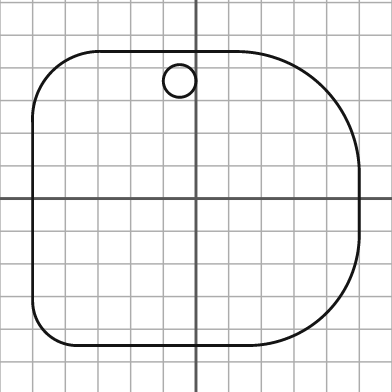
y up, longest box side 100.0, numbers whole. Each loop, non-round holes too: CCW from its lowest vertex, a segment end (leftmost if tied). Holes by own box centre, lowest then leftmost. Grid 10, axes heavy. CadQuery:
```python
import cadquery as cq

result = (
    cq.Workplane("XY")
    .moveTo(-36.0, -45.0)
    .lineTo(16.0, -45.0)
    .threePointArc((40.0, -35.0), (50.0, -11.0))
    .lineTo(50.0, 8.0)
    .threePointArc((39.0, 34.0), (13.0, 45.0))
    .lineTo(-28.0, 45.0)
    .threePointArc((-44.0, 39.0), (-50.0, 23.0))
    .lineTo(-50.0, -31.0)
    .threePointArc((-46.0, -41.0), (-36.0, -45.0))
    .close()
    .moveTo(-5.0, 36.0)
    .circle(5.0)
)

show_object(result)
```